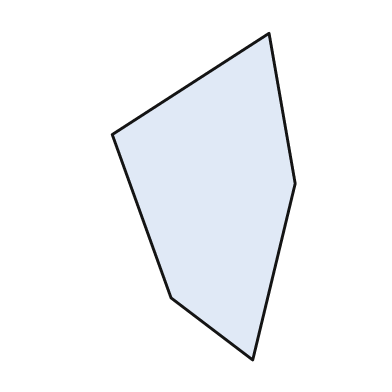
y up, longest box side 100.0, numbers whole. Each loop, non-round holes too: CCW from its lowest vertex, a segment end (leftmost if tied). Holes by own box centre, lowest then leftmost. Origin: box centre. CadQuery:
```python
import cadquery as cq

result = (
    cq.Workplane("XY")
    .moveTo(15.0, -50.0)
    .lineTo(28.0, 4.0)
    .lineTo(20.0, 50.0)
    .lineTo(-28.0, 19.0)
    .lineTo(-10.0, -31.0)
    .close()
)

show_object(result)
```